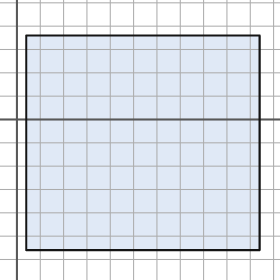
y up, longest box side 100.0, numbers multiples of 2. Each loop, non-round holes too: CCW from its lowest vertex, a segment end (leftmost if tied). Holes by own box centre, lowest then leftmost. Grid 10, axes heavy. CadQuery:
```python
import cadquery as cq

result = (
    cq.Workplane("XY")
    .moveTo(4.0, -56.0)
    .lineTo(104.0, -56.0)
    .lineTo(104.0, 36.0)
    .lineTo(4.0, 36.0)
    .close()
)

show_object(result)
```